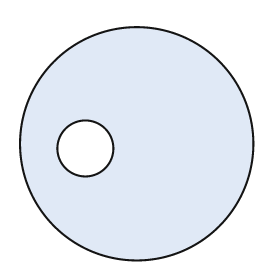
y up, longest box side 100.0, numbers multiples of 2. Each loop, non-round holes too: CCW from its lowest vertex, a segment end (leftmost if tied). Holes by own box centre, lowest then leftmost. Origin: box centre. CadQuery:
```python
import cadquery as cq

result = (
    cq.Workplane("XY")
    .moveTo(0.0, 0.0)
    .circle(50.0)
    .moveTo(-22.0, -2.0)
    .circle(12.0)
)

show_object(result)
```